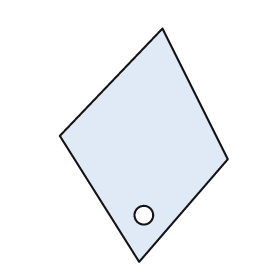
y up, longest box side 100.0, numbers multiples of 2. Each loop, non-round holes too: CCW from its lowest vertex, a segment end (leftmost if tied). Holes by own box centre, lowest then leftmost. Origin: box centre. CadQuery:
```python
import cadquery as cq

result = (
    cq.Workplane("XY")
    .moveTo(-2.0, -50.0)
    .lineTo(36.0, -6.0)
    .lineTo(8.0, 50.0)
    .lineTo(-36.0, 4.0)
    .close()
    .moveTo(0.0, -30.0)
    .circle(4.0)
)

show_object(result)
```